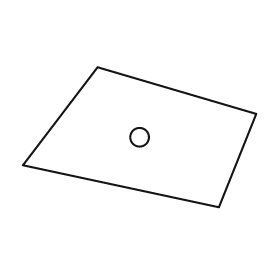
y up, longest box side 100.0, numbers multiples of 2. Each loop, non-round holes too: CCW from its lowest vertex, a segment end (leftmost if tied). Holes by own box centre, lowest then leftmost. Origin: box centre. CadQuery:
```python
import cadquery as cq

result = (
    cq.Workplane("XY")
    .moveTo(34.0, -30.0)
    .lineTo(50.0, 10.0)
    .lineTo(-18.0, 30.0)
    .lineTo(-50.0, -12.0)
    .close()
    .moveTo(0.0, 0.0)
    .circle(4.0)
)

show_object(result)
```